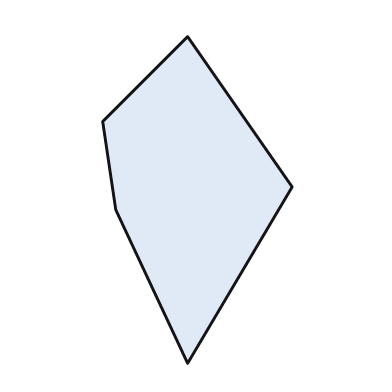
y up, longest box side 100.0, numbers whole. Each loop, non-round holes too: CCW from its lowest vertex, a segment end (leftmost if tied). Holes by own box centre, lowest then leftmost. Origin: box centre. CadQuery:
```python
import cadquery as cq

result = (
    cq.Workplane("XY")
    .moveTo(-3.0, -50.0)
    .lineTo(29.0, 4.0)
    .lineTo(-3.0, 50.0)
    .lineTo(-29.0, 24.0)
    .lineTo(-25.0, -3.0)
    .close()
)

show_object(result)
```